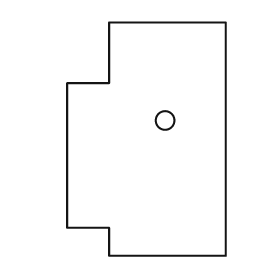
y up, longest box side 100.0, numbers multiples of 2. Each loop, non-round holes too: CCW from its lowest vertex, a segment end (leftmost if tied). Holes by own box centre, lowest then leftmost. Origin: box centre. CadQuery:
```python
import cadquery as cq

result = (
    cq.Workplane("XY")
    .moveTo(-16.0, -50.0)
    .lineTo(34.0, -50.0)
    .lineTo(34.0, 50.0)
    .lineTo(-16.0, 50.0)
    .lineTo(-16.0, 24.0)
    .lineTo(-34.0, 24.0)
    .lineTo(-34.0, -38.0)
    .lineTo(-16.0, -38.0)
    .close()
    .moveTo(8.0, 8.0)
    .circle(4.0)
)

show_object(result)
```